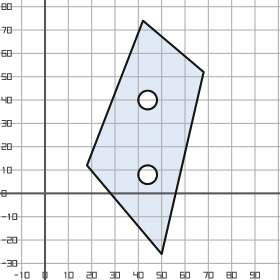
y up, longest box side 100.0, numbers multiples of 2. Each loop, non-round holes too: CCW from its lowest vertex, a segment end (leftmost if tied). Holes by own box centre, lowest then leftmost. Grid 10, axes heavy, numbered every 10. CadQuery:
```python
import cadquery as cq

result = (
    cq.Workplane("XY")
    .moveTo(50.0, -26.0)
    .lineTo(68.0, 52.0)
    .lineTo(42.0, 74.0)
    .lineTo(18.0, 12.0)
    .close()
    .moveTo(44.0, 8.0)
    .circle(4.0)
    .moveTo(44.0, 40.0)
    .circle(4.0)
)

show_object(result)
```